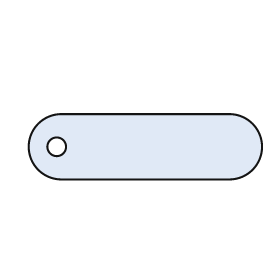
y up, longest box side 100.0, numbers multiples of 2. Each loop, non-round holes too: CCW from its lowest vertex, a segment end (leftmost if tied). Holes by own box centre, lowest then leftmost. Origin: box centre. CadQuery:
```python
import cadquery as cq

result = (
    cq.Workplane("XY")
    .moveTo(-36.0, -14.0)
    .lineTo(36.0, -14.0)
    .threePointArc((50.0, 0.0), (36.0, 14.0))
    .lineTo(-36.0, 14.0)
    .threePointArc((-50.0, 0.0), (-36.0, -14.0))
    .close()
    .moveTo(-38.0, 0.0)
    .circle(4.0)
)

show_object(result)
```